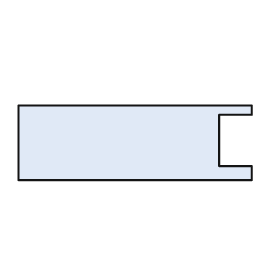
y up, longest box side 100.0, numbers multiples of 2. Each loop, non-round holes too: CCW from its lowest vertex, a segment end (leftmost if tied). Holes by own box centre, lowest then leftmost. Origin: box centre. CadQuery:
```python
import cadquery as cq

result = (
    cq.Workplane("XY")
    .moveTo(-50.0, -16.0)
    .lineTo(50.0, -16.0)
    .lineTo(50.0, -10.0)
    .lineTo(36.0, -10.0)
    .lineTo(36.0, 12.0)
    .lineTo(50.0, 12.0)
    .lineTo(50.0, 16.0)
    .lineTo(-50.0, 16.0)
    .close()
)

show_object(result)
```